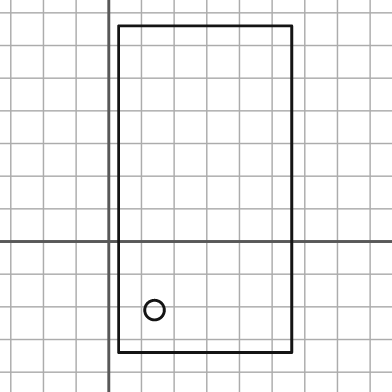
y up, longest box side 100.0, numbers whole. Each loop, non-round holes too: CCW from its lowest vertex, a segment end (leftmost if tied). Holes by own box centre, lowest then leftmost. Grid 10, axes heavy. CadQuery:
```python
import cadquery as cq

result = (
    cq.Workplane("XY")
    .moveTo(3.0, -34.0)
    .lineTo(56.0, -34.0)
    .lineTo(56.0, 66.0)
    .lineTo(3.0, 66.0)
    .close()
    .moveTo(14.0, -21.0)
    .circle(3.0)
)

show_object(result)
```